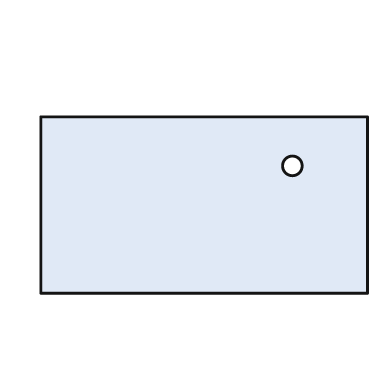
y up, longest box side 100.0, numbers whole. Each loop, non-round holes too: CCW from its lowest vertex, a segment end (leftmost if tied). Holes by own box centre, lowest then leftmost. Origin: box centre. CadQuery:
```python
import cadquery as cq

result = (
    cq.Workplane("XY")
    .moveTo(-50.0, -27.0)
    .lineTo(50.0, -27.0)
    .lineTo(50.0, 27.0)
    .lineTo(-50.0, 27.0)
    .close()
    .moveTo(27.0, 12.0)
    .circle(3.0)
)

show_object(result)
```